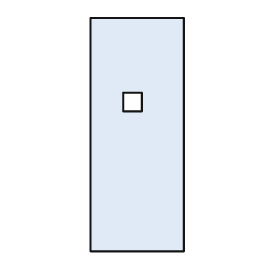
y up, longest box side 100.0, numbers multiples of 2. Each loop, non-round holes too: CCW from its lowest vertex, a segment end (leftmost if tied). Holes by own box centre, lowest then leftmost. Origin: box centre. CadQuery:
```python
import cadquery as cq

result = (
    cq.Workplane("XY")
    .moveTo(-20.0, -50.0)
    .lineTo(20.0, -50.0)
    .lineTo(20.0, 50.0)
    .lineTo(-20.0, 50.0)
    .close()
    .moveTo(-6.0, 10.0)
    .lineTo(2.0, 10.0)
    .lineTo(2.0, 18.0)
    .lineTo(-6.0, 18.0)
    .close()
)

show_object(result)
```